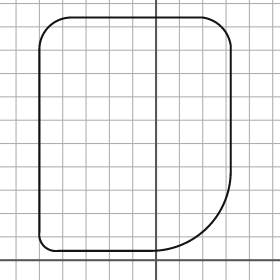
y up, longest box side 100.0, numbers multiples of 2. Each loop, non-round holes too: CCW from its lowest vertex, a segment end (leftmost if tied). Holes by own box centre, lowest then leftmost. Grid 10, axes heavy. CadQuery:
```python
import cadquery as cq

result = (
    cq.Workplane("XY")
    .moveTo(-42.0, 4.0)
    .lineTo(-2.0, 4.0)
    .threePointArc((22.0, 14.0), (32.0, 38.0))
    .lineTo(32.0, 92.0)
    .threePointArc((28.0, 100.0), (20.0, 104.0))
    .lineTo(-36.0, 104.0)
    .threePointArc((-46.0, 100.0), (-50.0, 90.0))
    .lineTo(-50.0, 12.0)
    .threePointArc((-48.0, 6.0), (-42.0, 4.0))
    .close()
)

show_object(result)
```